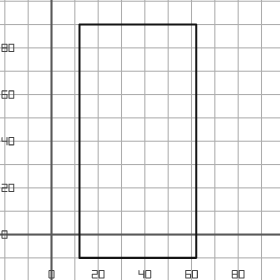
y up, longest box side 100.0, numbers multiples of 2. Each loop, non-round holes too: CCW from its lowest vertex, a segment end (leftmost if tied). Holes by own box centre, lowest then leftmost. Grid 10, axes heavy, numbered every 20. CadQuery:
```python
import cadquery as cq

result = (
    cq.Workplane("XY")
    .moveTo(12.0, -10.0)
    .lineTo(62.0, -10.0)
    .lineTo(62.0, 90.0)
    .lineTo(12.0, 90.0)
    .close()
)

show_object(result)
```